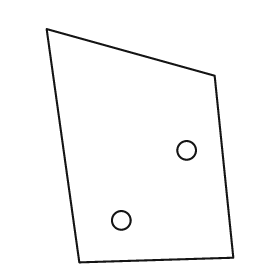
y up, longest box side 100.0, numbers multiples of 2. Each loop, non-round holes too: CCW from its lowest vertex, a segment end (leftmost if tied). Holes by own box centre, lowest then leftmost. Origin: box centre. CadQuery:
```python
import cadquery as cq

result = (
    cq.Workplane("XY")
    .moveTo(-26.0, -50.0)
    .lineTo(40.0, -48.0)
    .lineTo(32.0, 30.0)
    .lineTo(-40.0, 50.0)
    .close()
    .moveTo(-8.0, -32.0)
    .circle(4.0)
    .moveTo(20.0, -2.0)
    .circle(4.0)
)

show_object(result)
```